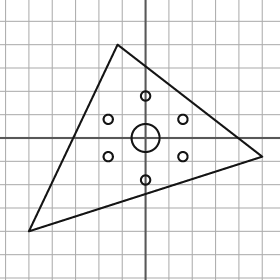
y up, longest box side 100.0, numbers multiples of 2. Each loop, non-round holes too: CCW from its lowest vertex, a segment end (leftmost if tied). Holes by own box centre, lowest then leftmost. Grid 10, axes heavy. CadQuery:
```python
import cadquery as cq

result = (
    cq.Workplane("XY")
    .moveTo(-50.0, -40.0)
    .lineTo(50.0, -8.0)
    .lineTo(-12.0, 40.0)
    .close()
    .moveTo(0.0, -18.0)
    .circle(2.0)
    .moveTo(-16.0, -8.0)
    .circle(2.0)
    .moveTo(16.0, -8.0)
    .circle(2.0)
    .moveTo(0.0, 0.0)
    .circle(6.0)
    .moveTo(-16.0, 8.0)
    .circle(2.0)
    .moveTo(16.0, 8.0)
    .circle(2.0)
    .moveTo(0.0, 18.0)
    .circle(2.0)
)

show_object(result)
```